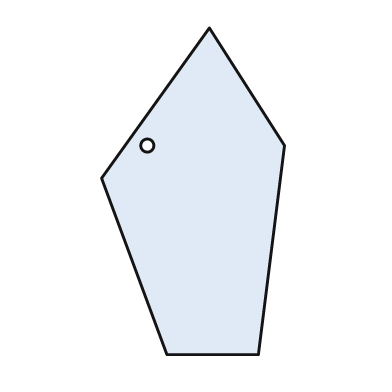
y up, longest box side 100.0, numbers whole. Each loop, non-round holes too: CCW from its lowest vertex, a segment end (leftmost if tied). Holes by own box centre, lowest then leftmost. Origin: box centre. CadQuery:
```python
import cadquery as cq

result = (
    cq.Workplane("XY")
    .moveTo(-8.0, -50.0)
    .lineTo(20.0, -50.0)
    .lineTo(28.0, 14.0)
    .lineTo(5.0, 50.0)
    .lineTo(-28.0, 4.0)
    .close()
    .moveTo(-14.0, 14.0)
    .circle(2.0)
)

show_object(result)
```